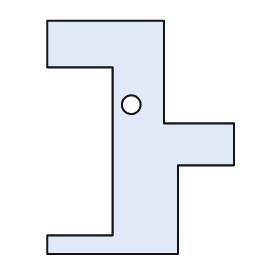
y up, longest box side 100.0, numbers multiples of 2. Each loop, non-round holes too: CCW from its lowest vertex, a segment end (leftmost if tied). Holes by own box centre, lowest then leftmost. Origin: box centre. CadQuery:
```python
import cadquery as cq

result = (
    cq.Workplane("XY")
    .moveTo(-40.0, -50.0)
    .lineTo(16.0, -50.0)
    .lineTo(16.0, -12.0)
    .lineTo(40.0, -12.0)
    .lineTo(40.0, 6.0)
    .lineTo(10.0, 6.0)
    .lineTo(10.0, 50.0)
    .lineTo(-40.0, 50.0)
    .lineTo(-40.0, 30.0)
    .lineTo(-12.0, 30.0)
    .lineTo(-12.0, -42.0)
    .lineTo(-40.0, -42.0)
    .close()
    .moveTo(-4.0, 14.0)
    .circle(4.0)
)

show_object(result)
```